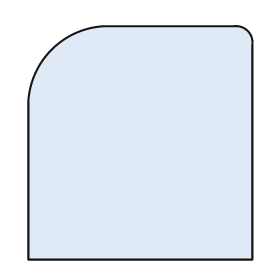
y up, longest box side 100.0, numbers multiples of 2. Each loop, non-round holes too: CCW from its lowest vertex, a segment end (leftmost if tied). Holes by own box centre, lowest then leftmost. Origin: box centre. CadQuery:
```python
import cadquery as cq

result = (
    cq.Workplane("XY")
    .moveTo(-48.0, -50.0)
    .lineTo(48.0, -50.0)
    .lineTo(48.0, 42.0)
    .threePointArc((46.0, 48.0), (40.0, 50.0))
    .lineTo(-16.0, 50.0)
    .threePointArc((-38.0, 40.0), (-48.0, 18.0))
    .close()
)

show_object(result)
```